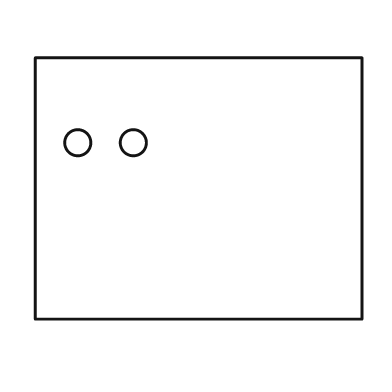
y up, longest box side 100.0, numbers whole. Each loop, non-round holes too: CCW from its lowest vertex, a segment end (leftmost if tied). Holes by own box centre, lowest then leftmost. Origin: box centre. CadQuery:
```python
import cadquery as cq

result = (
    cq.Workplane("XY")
    .moveTo(-50.0, -40.0)
    .lineTo(50.0, -40.0)
    .lineTo(50.0, 40.0)
    .lineTo(-50.0, 40.0)
    .close()
    .moveTo(-37.0, 14.0)
    .circle(4.0)
    .moveTo(-20.0, 14.0)
    .circle(4.0)
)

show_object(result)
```